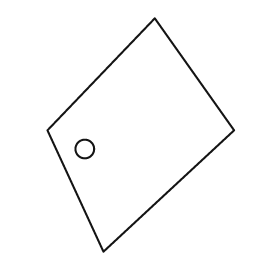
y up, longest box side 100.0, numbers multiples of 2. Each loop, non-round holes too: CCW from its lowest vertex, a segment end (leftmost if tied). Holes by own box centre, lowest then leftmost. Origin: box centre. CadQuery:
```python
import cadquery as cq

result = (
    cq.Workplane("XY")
    .moveTo(-16.0, -50.0)
    .lineTo(40.0, 2.0)
    .lineTo(6.0, 50.0)
    .lineTo(-40.0, 2.0)
    .close()
    .moveTo(-24.0, -6.0)
    .circle(4.0)
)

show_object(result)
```